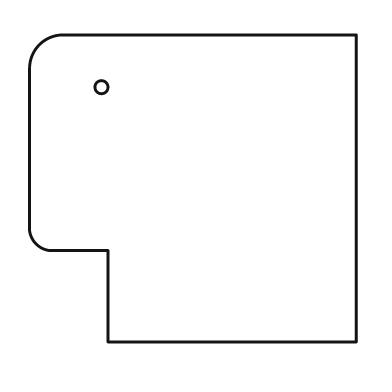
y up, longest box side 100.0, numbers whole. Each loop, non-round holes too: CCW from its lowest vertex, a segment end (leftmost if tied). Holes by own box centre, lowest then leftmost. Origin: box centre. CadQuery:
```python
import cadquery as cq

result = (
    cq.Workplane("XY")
    .moveTo(-26.0, -47.0)
    .lineTo(50.0, -47.0)
    .lineTo(50.0, 47.0)
    .lineTo(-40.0, 47.0)
    .threePointArc((-47.0, 44.0), (-50.0, 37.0))
    .lineTo(-50.0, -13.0)
    .threePointArc((-48.0, -17.0), (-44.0, -19.0))
    .lineTo(-26.0, -19.0)
    .close()
    .moveTo(-28.0, 31.0)
    .circle(2.0)
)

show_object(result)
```